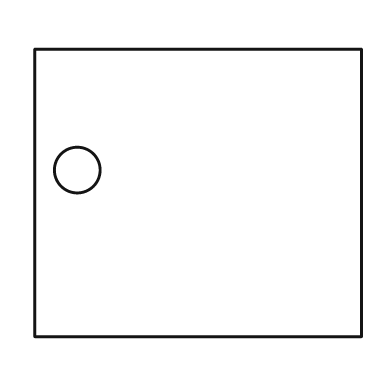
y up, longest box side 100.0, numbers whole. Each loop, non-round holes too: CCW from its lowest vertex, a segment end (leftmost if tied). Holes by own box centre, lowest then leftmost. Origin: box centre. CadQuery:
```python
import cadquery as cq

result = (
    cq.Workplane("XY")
    .moveTo(-50.0, -44.0)
    .lineTo(50.0, -44.0)
    .lineTo(50.0, 44.0)
    .lineTo(-50.0, 44.0)
    .close()
    .moveTo(-37.0, 7.0)
    .circle(7.0)
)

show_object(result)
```